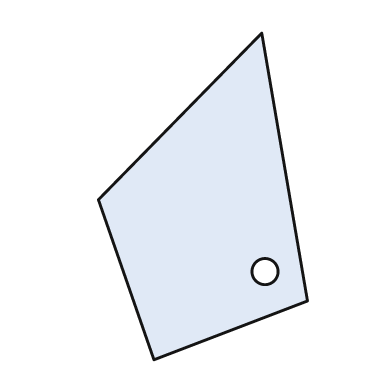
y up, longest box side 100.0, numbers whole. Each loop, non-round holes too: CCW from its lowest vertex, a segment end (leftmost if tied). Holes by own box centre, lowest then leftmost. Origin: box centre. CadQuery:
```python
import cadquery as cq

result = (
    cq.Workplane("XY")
    .moveTo(-15.0, -50.0)
    .lineTo(32.0, -32.0)
    .lineTo(18.0, 50.0)
    .lineTo(-32.0, -1.0)
    .close()
    .moveTo(19.0, -23.0)
    .circle(4.0)
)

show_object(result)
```